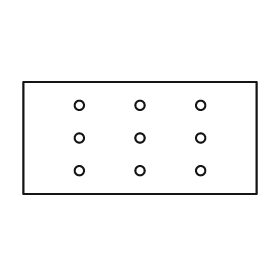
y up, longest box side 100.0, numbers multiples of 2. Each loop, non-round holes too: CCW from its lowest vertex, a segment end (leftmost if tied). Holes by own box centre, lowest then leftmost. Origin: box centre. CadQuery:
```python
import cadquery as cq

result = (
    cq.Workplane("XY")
    .moveTo(-50.0, -24.0)
    .lineTo(50.0, -24.0)
    .lineTo(50.0, 24.0)
    .lineTo(-50.0, 24.0)
    .close()
    .moveTo(-26.0, -14.0)
    .circle(2.0)
    .moveTo(0.0, -14.0)
    .circle(2.0)
    .moveTo(26.0, -14.0)
    .circle(2.0)
    .moveTo(-26.0, 0.0)
    .circle(2.0)
    .moveTo(0.0, 0.0)
    .circle(2.0)
    .moveTo(26.0, 0.0)
    .circle(2.0)
    .moveTo(-26.0, 14.0)
    .circle(2.0)
    .moveTo(0.0, 14.0)
    .circle(2.0)
    .moveTo(26.0, 14.0)
    .circle(2.0)
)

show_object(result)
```